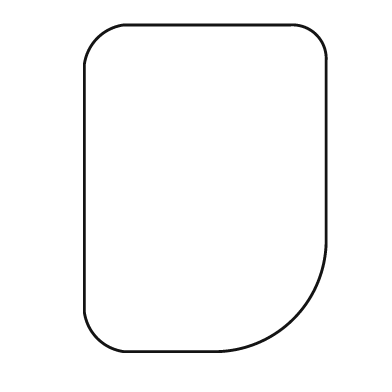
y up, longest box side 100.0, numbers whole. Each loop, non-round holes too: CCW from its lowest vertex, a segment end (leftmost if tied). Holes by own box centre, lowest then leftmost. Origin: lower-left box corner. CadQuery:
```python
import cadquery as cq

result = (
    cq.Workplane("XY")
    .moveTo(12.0, 0.0)
    .lineTo(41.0, 0.0)
    .threePointArc((64.0, 10.0), (74.0, 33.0))
    .lineTo(74.0, 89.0)
    .threePointArc((71.0, 97.0), (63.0, 100.0))
    .lineTo(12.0, 100.0)
    .threePointArc((4.0, 96.0), (0.0, 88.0))
    .lineTo(0.0, 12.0)
    .threePointArc((4.0, 4.0), (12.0, 0.0))
    .close()
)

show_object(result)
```